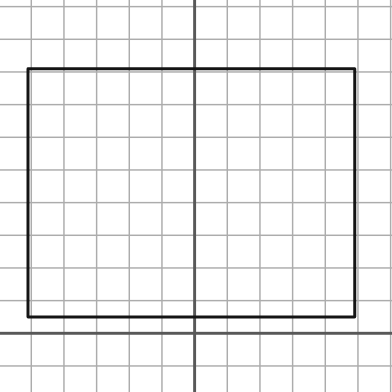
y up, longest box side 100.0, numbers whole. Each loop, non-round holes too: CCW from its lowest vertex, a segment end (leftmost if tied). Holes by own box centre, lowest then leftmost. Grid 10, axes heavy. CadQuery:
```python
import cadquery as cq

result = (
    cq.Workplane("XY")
    .moveTo(-51.0, 5.0)
    .lineTo(49.0, 5.0)
    .lineTo(49.0, 81.0)
    .lineTo(-51.0, 81.0)
    .close()
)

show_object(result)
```